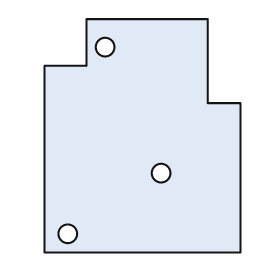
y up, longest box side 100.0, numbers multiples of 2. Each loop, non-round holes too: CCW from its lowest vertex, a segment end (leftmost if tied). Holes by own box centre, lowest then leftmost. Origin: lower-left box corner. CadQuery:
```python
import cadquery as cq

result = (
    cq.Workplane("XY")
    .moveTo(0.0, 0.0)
    .lineTo(84.0, 0.0)
    .lineTo(84.0, 64.0)
    .lineTo(70.0, 64.0)
    .lineTo(70.0, 100.0)
    .lineTo(18.0, 100.0)
    .lineTo(18.0, 80.0)
    .lineTo(0.0, 80.0)
    .close()
    .moveTo(10.0, 8.0)
    .circle(4.0)
    .moveTo(50.0, 34.0)
    .circle(4.0)
    .moveTo(26.0, 88.0)
    .circle(4.0)
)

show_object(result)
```